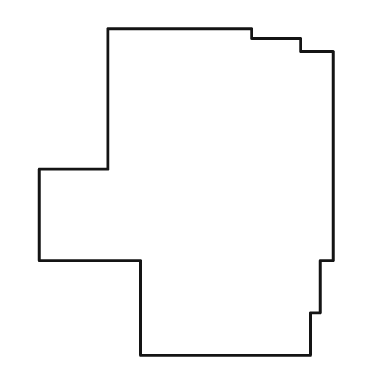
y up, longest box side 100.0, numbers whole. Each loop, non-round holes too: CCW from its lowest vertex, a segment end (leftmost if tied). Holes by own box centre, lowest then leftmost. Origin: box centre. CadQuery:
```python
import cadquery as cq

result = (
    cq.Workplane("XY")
    .moveTo(-14.0, -50.0)
    .lineTo(38.0, -50.0)
    .lineTo(38.0, -37.0)
    .lineTo(41.0, -37.0)
    .lineTo(41.0, -21.0)
    .lineTo(45.0, -21.0)
    .lineTo(45.0, 43.0)
    .lineTo(35.0, 43.0)
    .lineTo(35.0, 47.0)
    .lineTo(20.0, 47.0)
    .lineTo(20.0, 50.0)
    .lineTo(-24.0, 50.0)
    .lineTo(-24.0, 7.0)
    .lineTo(-45.0, 7.0)
    .lineTo(-45.0, -21.0)
    .lineTo(-14.0, -21.0)
    .close()
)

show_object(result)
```